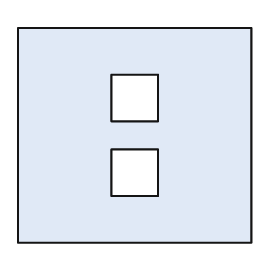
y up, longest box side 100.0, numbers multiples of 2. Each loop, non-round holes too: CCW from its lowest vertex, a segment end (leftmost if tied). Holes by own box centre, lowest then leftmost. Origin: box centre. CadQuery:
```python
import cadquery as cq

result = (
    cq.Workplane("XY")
    .moveTo(-50.0, -46.0)
    .lineTo(50.0, -46.0)
    .lineTo(50.0, 46.0)
    .lineTo(-50.0, 46.0)
    .close()
    .moveTo(-10.0, -26.0)
    .lineTo(10.0, -26.0)
    .lineTo(10.0, -6.0)
    .lineTo(-10.0, -6.0)
    .close()
    .moveTo(-10.0, 6.0)
    .lineTo(10.0, 6.0)
    .lineTo(10.0, 26.0)
    .lineTo(-10.0, 26.0)
    .close()
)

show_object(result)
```